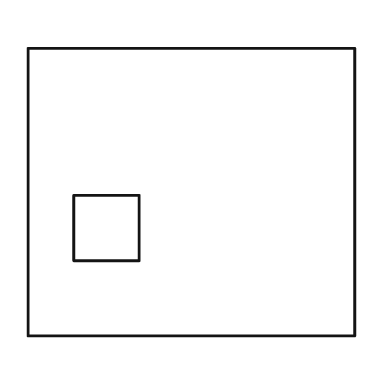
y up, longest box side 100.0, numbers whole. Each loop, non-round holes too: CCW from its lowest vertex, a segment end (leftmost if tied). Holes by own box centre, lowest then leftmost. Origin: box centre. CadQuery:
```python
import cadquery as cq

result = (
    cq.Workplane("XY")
    .moveTo(-50.0, -44.0)
    .lineTo(50.0, -44.0)
    .lineTo(50.0, 44.0)
    .lineTo(-50.0, 44.0)
    .close()
    .moveTo(-36.0, -21.0)
    .lineTo(-16.0, -21.0)
    .lineTo(-16.0, -1.0)
    .lineTo(-36.0, -1.0)
    .close()
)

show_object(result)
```